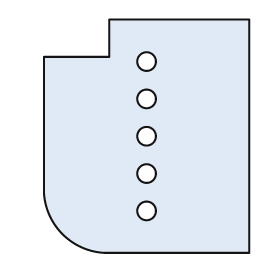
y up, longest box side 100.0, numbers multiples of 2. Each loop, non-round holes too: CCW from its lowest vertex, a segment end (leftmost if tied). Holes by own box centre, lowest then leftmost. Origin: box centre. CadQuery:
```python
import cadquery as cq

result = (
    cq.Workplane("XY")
    .moveTo(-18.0, -50.0)
    .lineTo(44.0, -50.0)
    .lineTo(44.0, 50.0)
    .lineTo(-16.0, 50.0)
    .lineTo(-16.0, 34.0)
    .lineTo(-44.0, 34.0)
    .lineTo(-44.0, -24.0)
    .threePointArc((-36.0, -42.0), (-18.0, -50.0))
    .close()
    .moveTo(0.0, -32.0)
    .circle(4.0)
    .moveTo(0.0, -16.0)
    .circle(4.0)
    .moveTo(0.0, 0.0)
    .circle(4.0)
    .moveTo(0.0, 16.0)
    .circle(4.0)
    .moveTo(0.0, 32.0)
    .circle(4.0)
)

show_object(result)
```